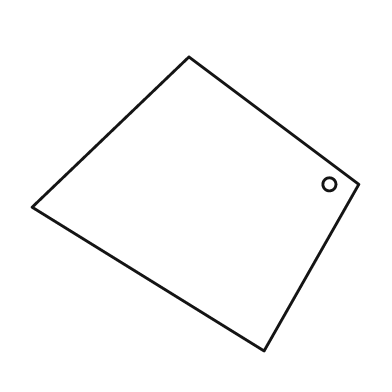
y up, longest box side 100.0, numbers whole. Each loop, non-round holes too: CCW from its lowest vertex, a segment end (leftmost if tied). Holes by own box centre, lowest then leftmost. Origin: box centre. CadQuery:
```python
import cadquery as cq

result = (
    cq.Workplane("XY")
    .moveTo(21.0, -45.0)
    .lineTo(50.0, 6.0)
    .lineTo(-2.0, 45.0)
    .lineTo(-50.0, -1.0)
    .close()
    .moveTo(41.0, 6.0)
    .circle(2.0)
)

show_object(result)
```